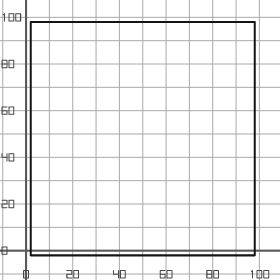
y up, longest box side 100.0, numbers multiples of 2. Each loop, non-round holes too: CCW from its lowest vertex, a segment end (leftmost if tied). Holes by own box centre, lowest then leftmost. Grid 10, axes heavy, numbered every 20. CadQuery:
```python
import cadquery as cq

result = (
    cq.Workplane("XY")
    .moveTo(2.0, -2.0)
    .lineTo(98.0, -2.0)
    .lineTo(98.0, 98.0)
    .lineTo(2.0, 98.0)
    .close()
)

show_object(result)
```